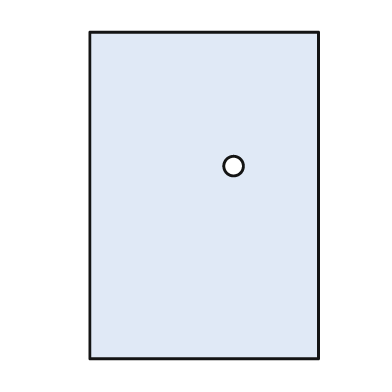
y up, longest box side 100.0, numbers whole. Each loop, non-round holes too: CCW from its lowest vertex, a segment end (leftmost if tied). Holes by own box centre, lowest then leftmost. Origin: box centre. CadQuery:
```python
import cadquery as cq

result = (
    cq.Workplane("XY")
    .moveTo(-35.0, -50.0)
    .lineTo(35.0, -50.0)
    .lineTo(35.0, 50.0)
    .lineTo(-35.0, 50.0)
    .close()
    .moveTo(9.0, 9.0)
    .circle(3.0)
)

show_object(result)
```